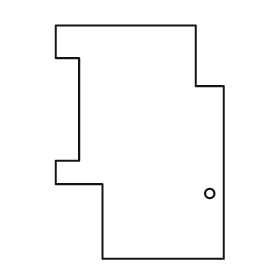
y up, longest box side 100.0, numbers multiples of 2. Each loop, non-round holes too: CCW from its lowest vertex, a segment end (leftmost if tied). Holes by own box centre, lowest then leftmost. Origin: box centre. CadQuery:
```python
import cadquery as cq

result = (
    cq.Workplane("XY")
    .moveTo(-16.0, -50.0)
    .lineTo(36.0, -50.0)
    .lineTo(36.0, 24.0)
    .lineTo(24.0, 24.0)
    .lineTo(24.0, 50.0)
    .lineTo(-36.0, 50.0)
    .lineTo(-36.0, 36.0)
    .lineTo(-26.0, 36.0)
    .lineTo(-26.0, -8.0)
    .lineTo(-36.0, -8.0)
    .lineTo(-36.0, -18.0)
    .lineTo(-16.0, -18.0)
    .close()
    .moveTo(30.0, -22.0)
    .circle(2.0)
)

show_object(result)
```